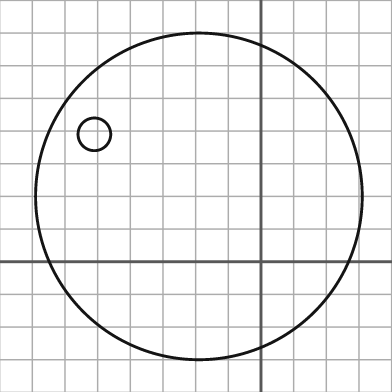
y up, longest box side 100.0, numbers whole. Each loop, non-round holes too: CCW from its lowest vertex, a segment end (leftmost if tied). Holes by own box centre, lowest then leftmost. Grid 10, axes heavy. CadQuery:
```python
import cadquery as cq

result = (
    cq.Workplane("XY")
    .moveTo(-19.0, 20.0)
    .circle(50.0)
    .moveTo(-51.0, 39.0)
    .circle(5.0)
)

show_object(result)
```